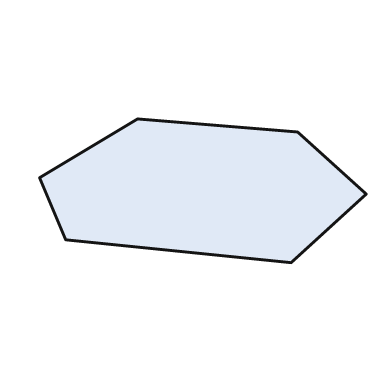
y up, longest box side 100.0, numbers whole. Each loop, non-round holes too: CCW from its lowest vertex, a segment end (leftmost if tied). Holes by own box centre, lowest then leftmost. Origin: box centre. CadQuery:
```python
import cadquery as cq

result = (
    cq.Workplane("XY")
    .moveTo(27.0, -22.0)
    .lineTo(50.0, -1.0)
    .lineTo(29.0, 18.0)
    .lineTo(-20.0, 22.0)
    .lineTo(-50.0, 4.0)
    .lineTo(-42.0, -15.0)
    .close()
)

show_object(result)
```